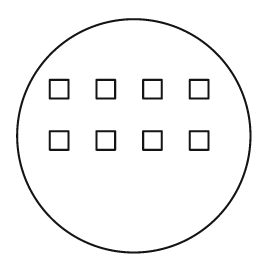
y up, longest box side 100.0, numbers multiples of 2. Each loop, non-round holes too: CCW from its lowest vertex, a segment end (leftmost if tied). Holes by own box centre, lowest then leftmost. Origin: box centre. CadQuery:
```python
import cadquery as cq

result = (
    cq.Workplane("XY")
    .moveTo(0.0, 0.0)
    .circle(50.0)
    .moveTo(-36.0, -6.0)
    .lineTo(-28.0, -6.0)
    .lineTo(-28.0, 2.0)
    .lineTo(-36.0, 2.0)
    .close()
    .moveTo(-16.0, -6.0)
    .lineTo(-8.0, -6.0)
    .lineTo(-8.0, 2.0)
    .lineTo(-16.0, 2.0)
    .close()
    .moveTo(4.0, -6.0)
    .lineTo(12.0, -6.0)
    .lineTo(12.0, 2.0)
    .lineTo(4.0, 2.0)
    .close()
    .moveTo(24.0, -6.0)
    .lineTo(32.0, -6.0)
    .lineTo(32.0, 2.0)
    .lineTo(24.0, 2.0)
    .close()
    .moveTo(-36.0, 16.0)
    .lineTo(-28.0, 16.0)
    .lineTo(-28.0, 24.0)
    .lineTo(-36.0, 24.0)
    .close()
    .moveTo(-16.0, 16.0)
    .lineTo(-8.0, 16.0)
    .lineTo(-8.0, 24.0)
    .lineTo(-16.0, 24.0)
    .close()
    .moveTo(4.0, 16.0)
    .lineTo(12.0, 16.0)
    .lineTo(12.0, 24.0)
    .lineTo(4.0, 24.0)
    .close()
    .moveTo(24.0, 16.0)
    .lineTo(32.0, 16.0)
    .lineTo(32.0, 24.0)
    .lineTo(24.0, 24.0)
    .close()
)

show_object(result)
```